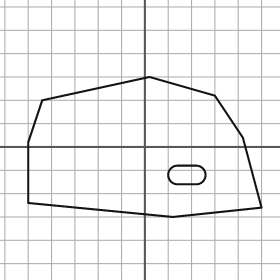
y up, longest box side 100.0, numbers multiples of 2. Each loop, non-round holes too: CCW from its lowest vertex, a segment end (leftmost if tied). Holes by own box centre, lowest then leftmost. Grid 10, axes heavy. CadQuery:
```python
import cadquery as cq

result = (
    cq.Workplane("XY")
    .moveTo(12.0, -30.0)
    .lineTo(50.0, -26.0)
    .lineTo(42.0, 4.0)
    .lineTo(30.0, 22.0)
    .lineTo(2.0, 30.0)
    .lineTo(-44.0, 20.0)
    .lineTo(-50.0, 2.0)
    .lineTo(-50.0, -24.0)
    .close()
    .moveTo(14.0, -16.0)
    .lineTo(22.0, -16.0)
    .threePointArc((26.0, -12.0), (22.0, -8.0))
    .lineTo(14.0, -8.0)
    .threePointArc((10.0, -12.0), (14.0, -16.0))
    .close()
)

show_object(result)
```